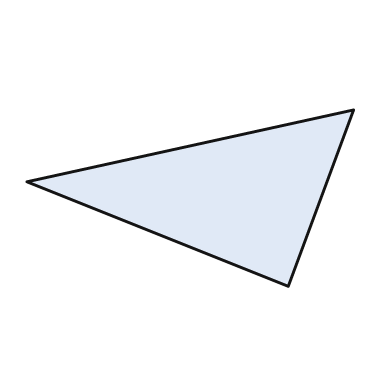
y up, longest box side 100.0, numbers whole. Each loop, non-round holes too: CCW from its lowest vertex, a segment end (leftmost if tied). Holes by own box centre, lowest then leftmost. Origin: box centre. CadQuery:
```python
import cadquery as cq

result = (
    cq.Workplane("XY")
    .moveTo(30.0, -27.0)
    .lineTo(50.0, 27.0)
    .lineTo(-50.0, 5.0)
    .close()
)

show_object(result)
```